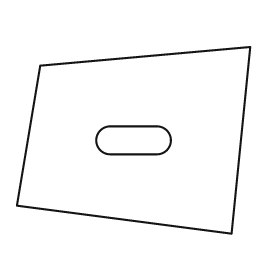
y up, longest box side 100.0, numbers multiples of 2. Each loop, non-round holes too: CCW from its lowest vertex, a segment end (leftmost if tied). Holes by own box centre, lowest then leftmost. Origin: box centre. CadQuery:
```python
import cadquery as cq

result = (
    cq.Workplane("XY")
    .moveTo(42.0, -40.0)
    .lineTo(50.0, 40.0)
    .lineTo(-40.0, 32.0)
    .lineTo(-50.0, -28.0)
    .close()
    .moveTo(-10.0, -6.0)
    .lineTo(10.0, -6.0)
    .threePointArc((16.0, 0.0), (10.0, 6.0))
    .lineTo(-10.0, 6.0)
    .threePointArc((-16.0, 0.0), (-10.0, -6.0))
    .close()
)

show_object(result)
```